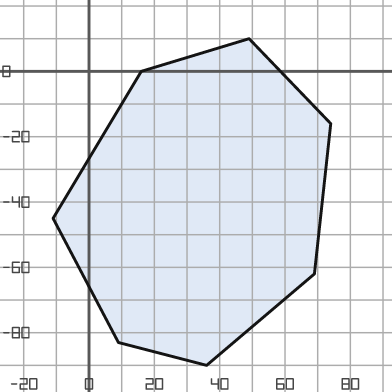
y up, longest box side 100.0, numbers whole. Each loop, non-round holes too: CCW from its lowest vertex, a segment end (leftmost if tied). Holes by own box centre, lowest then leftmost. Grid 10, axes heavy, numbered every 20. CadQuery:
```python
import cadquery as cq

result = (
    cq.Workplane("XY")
    .moveTo(36.0, -90.0)
    .lineTo(69.0, -62.0)
    .lineTo(74.0, -16.0)
    .lineTo(49.0, 10.0)
    .lineTo(16.0, 0.0)
    .lineTo(-11.0, -45.0)
    .lineTo(9.0, -83.0)
    .close()
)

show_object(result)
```